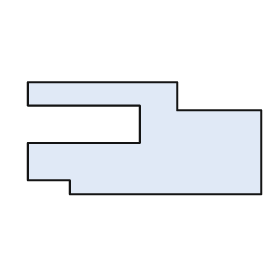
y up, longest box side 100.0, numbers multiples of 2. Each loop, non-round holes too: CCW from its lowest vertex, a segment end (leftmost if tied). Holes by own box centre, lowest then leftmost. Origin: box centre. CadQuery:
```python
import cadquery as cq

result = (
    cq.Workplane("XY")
    .moveTo(-32.0, -24.0)
    .lineTo(50.0, -24.0)
    .lineTo(50.0, 12.0)
    .lineTo(14.0, 12.0)
    .lineTo(14.0, 24.0)
    .lineTo(-50.0, 24.0)
    .lineTo(-50.0, 14.0)
    .lineTo(-2.0, 14.0)
    .lineTo(-2.0, -2.0)
    .lineTo(-50.0, -2.0)
    .lineTo(-50.0, -18.0)
    .lineTo(-32.0, -18.0)
    .close()
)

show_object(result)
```